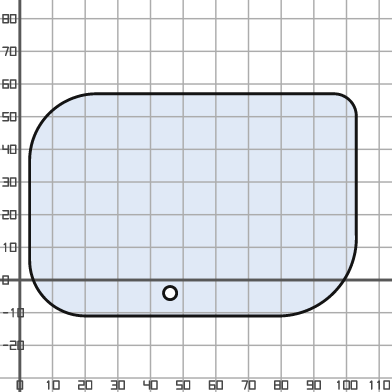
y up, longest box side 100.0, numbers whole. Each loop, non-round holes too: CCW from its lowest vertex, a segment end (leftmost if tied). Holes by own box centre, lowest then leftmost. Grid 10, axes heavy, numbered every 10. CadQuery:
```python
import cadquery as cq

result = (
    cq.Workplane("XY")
    .moveTo(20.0, -11.0)
    .lineTo(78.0, -11.0)
    .threePointArc((96.0, -4.0), (103.0, 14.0))
    .lineTo(103.0, 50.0)
    .threePointArc((101.0, 55.0), (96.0, 57.0))
    .lineTo(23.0, 57.0)
    .threePointArc((9.0, 51.0), (3.0, 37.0))
    .lineTo(3.0, 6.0)
    .threePointArc((8.0, -6.0), (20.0, -11.0))
    .close()
    .moveTo(46.0, -4.0)
    .circle(2.0)
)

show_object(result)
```